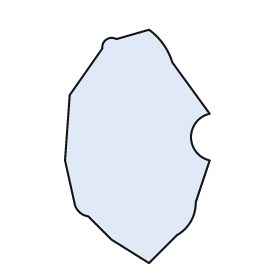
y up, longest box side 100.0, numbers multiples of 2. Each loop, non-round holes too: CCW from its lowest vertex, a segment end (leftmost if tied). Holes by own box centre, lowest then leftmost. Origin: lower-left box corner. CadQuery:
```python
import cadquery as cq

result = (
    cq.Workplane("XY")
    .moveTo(36.0, 0.0)
    .lineTo(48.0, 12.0)
    .threePointArc((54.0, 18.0), (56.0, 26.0))
    .lineTo(62.0, 44.0)
    .threePointArc((54.0, 54.0), (62.0, 64.0))
    .lineTo(46.0, 86.0)
    .threePointArc((42.0, 94.0), (36.0, 100.0))
    .lineTo(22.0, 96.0)
    .threePointArc((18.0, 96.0), (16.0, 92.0))
    .lineTo(2.0, 72.0)
    .lineTo(0.0, 44.0)
    .lineTo(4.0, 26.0)
    .threePointArc((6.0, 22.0), (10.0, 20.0))
    .lineTo(20.0, 10.0)
    .close()
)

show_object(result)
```